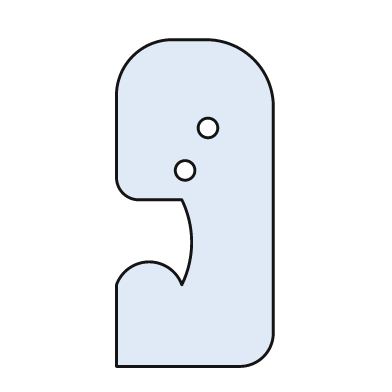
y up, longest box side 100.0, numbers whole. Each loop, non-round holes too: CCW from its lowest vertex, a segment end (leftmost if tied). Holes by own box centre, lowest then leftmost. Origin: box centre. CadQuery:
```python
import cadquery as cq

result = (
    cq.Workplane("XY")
    .moveTo(-24.0, -50.0)
    .lineTo(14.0, -50.0)
    .threePointArc((21.0, -47.0), (24.0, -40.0))
    .lineTo(24.0, 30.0)
    .threePointArc((18.0, 44.0), (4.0, 50.0))
    .lineTo(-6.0, 50.0)
    .threePointArc((-19.0, 45.0), (-24.0, 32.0))
    .lineTo(-24.0, 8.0)
    .threePointArc((-22.0, 3.0), (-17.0, 1.0))
    .lineTo(-4.0, 1.0)
    .threePointArc((-1.0, -12.0), (-4.0, -25.0))
    .threePointArc((-14.0, -18.0), (-24.0, -25.0))
    .close()
    .moveTo(-3.0, 10.0)
    .circle(3.0)
    .moveTo(4.0, 23.0)
    .circle(3.0)
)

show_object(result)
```